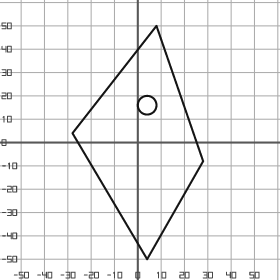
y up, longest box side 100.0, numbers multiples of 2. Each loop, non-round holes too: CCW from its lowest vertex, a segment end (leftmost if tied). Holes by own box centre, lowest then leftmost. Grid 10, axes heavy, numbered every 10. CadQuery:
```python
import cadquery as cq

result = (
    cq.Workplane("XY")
    .moveTo(4.0, -50.0)
    .lineTo(28.0, -8.0)
    .lineTo(8.0, 50.0)
    .lineTo(-28.0, 4.0)
    .close()
    .moveTo(4.0, 16.0)
    .circle(4.0)
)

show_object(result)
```